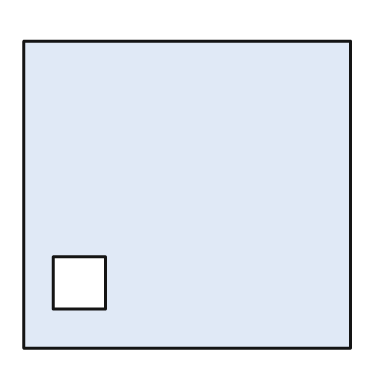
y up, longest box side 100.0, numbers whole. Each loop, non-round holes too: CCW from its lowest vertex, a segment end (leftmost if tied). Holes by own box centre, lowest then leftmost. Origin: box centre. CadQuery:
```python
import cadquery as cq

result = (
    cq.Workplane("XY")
    .moveTo(-50.0, -47.0)
    .lineTo(50.0, -47.0)
    .lineTo(50.0, 47.0)
    .lineTo(-50.0, 47.0)
    .close()
    .moveTo(-41.0, -35.0)
    .lineTo(-25.0, -35.0)
    .lineTo(-25.0, -19.0)
    .lineTo(-41.0, -19.0)
    .close()
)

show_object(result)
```